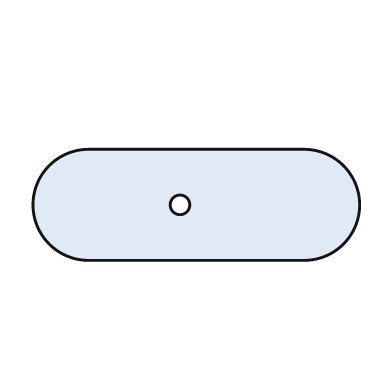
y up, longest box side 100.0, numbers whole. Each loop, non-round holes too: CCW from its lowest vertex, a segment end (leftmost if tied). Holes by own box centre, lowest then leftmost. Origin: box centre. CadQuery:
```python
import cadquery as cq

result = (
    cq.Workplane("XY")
    .moveTo(-33.0, -17.0)
    .lineTo(33.0, -17.0)
    .threePointArc((50.0, 0.0), (33.0, 17.0))
    .lineTo(-33.0, 17.0)
    .threePointArc((-50.0, 0.0), (-33.0, -17.0))
    .close()
    .moveTo(-5.0, 0.0)
    .circle(3.0)
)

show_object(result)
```